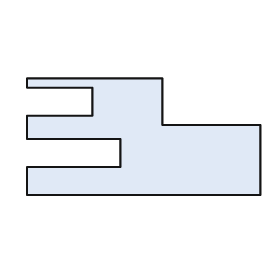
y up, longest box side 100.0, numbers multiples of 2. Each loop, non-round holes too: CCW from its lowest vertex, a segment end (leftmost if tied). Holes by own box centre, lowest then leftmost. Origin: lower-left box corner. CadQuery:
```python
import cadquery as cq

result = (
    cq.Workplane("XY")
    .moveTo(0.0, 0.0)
    .lineTo(100.0, 0.0)
    .lineTo(100.0, 30.0)
    .lineTo(58.0, 30.0)
    .lineTo(58.0, 50.0)
    .lineTo(0.0, 50.0)
    .lineTo(0.0, 46.0)
    .lineTo(28.0, 46.0)
    .lineTo(28.0, 34.0)
    .lineTo(0.0, 34.0)
    .lineTo(0.0, 24.0)
    .lineTo(40.0, 24.0)
    .lineTo(40.0, 12.0)
    .lineTo(0.0, 12.0)
    .close()
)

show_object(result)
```